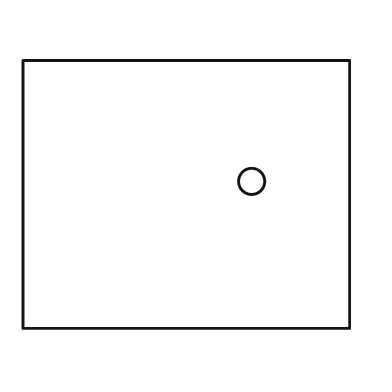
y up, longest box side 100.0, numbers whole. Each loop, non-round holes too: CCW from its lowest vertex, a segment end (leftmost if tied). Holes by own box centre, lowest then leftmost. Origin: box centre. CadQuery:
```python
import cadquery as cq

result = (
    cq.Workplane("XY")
    .moveTo(-50.0, -41.0)
    .lineTo(50.0, -41.0)
    .lineTo(50.0, 41.0)
    .lineTo(-50.0, 41.0)
    .close()
    .moveTo(20.0, 4.0)
    .circle(4.0)
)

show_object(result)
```